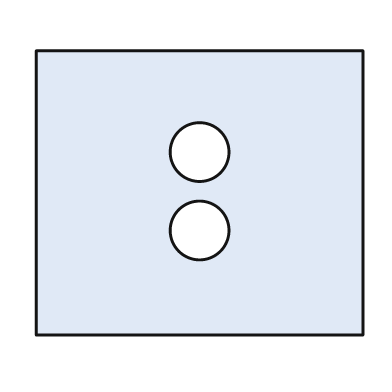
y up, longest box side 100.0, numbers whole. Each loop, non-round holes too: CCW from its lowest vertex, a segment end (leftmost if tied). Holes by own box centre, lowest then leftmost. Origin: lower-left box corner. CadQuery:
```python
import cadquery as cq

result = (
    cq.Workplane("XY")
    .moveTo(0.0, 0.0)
    .lineTo(100.0, 0.0)
    .lineTo(100.0, 87.0)
    .lineTo(0.0, 87.0)
    .close()
    .moveTo(50.0, 32.0)
    .circle(9.0)
    .moveTo(50.0, 56.0)
    .circle(9.0)
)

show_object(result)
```